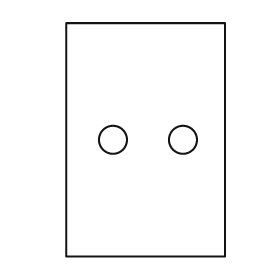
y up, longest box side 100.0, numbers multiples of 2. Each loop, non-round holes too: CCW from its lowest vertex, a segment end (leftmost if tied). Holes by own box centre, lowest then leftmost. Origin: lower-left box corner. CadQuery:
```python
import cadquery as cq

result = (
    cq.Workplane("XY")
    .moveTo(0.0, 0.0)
    .lineTo(68.0, 0.0)
    .lineTo(68.0, 100.0)
    .lineTo(0.0, 100.0)
    .close()
    .moveTo(20.0, 50.0)
    .circle(6.0)
    .moveTo(50.0, 50.0)
    .circle(6.0)
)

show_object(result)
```